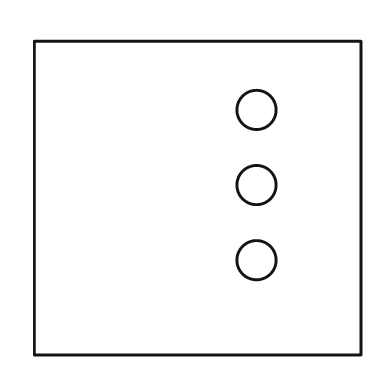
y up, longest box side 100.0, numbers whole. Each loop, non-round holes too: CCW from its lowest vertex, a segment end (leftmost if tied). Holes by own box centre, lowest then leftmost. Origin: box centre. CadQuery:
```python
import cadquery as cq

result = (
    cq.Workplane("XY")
    .moveTo(-50.0, -48.0)
    .lineTo(50.0, -48.0)
    .lineTo(50.0, 48.0)
    .lineTo(-50.0, 48.0)
    .close()
    .moveTo(18.0, -19.0)
    .circle(6.0)
    .moveTo(18.0, 4.0)
    .circle(6.0)
    .moveTo(18.0, 27.0)
    .circle(6.0)
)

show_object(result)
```